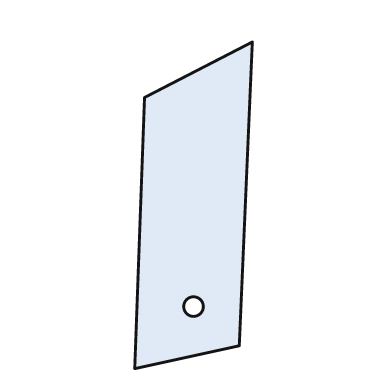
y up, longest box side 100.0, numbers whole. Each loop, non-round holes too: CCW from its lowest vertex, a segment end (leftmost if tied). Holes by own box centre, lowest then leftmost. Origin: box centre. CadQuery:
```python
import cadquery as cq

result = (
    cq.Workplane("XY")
    .moveTo(-18.0, -50.0)
    .lineTo(14.0, -43.0)
    .lineTo(18.0, 50.0)
    .lineTo(-15.0, 33.0)
    .close()
    .moveTo(0.0, -31.0)
    .circle(3.0)
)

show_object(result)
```